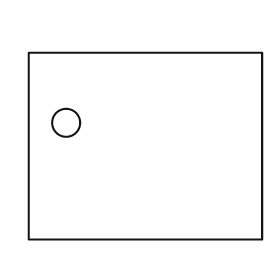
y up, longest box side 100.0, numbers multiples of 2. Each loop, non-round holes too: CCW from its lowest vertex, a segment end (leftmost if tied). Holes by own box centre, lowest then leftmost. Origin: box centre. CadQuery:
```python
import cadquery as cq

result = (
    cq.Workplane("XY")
    .moveTo(-50.0, -40.0)
    .lineTo(50.0, -40.0)
    .lineTo(50.0, 40.0)
    .lineTo(-50.0, 40.0)
    .close()
    .moveTo(-34.0, 10.0)
    .circle(6.0)
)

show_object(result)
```